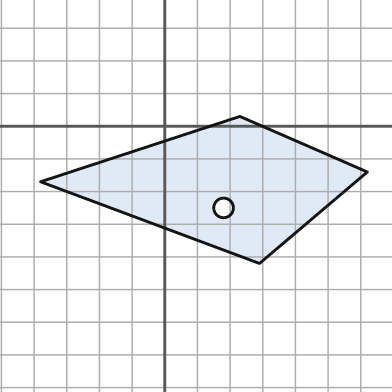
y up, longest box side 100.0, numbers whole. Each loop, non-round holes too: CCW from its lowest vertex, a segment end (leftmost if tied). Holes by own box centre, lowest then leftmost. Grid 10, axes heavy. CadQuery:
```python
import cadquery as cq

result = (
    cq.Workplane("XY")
    .moveTo(29.0, -42.0)
    .lineTo(62.0, -14.0)
    .lineTo(23.0, 3.0)
    .lineTo(-38.0, -17.0)
    .close()
    .moveTo(18.0, -25.0)
    .circle(3.0)
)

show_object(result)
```